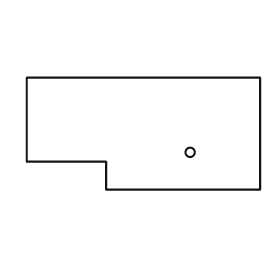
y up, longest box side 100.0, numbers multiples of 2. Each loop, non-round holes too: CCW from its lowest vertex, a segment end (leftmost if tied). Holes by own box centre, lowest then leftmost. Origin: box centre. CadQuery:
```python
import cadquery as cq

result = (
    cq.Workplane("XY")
    .moveTo(-16.0, -24.0)
    .lineTo(50.0, -24.0)
    .lineTo(50.0, 24.0)
    .lineTo(-50.0, 24.0)
    .lineTo(-50.0, -12.0)
    .lineTo(-16.0, -12.0)
    .close()
    .moveTo(20.0, -8.0)
    .circle(2.0)
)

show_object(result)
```